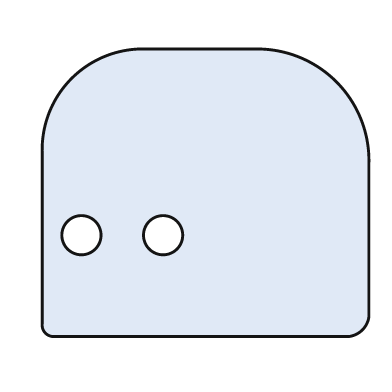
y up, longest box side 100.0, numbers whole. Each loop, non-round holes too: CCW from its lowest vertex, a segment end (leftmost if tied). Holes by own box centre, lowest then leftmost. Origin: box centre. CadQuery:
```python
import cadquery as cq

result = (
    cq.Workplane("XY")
    .moveTo(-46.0, -44.0)
    .lineTo(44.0, -44.0)
    .threePointArc((48.0, -42.0), (50.0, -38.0))
    .lineTo(50.0, 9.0)
    .threePointArc((40.0, 34.0), (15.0, 44.0))
    .lineTo(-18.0, 44.0)
    .threePointArc((-41.0, 35.0), (-50.0, 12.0))
    .lineTo(-50.0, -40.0)
    .threePointArc((-49.0, -43.0), (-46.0, -44.0))
    .close()
    .moveTo(-38.0, -13.0)
    .circle(6.0)
    .moveTo(-13.0, -13.0)
    .circle(6.0)
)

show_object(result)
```